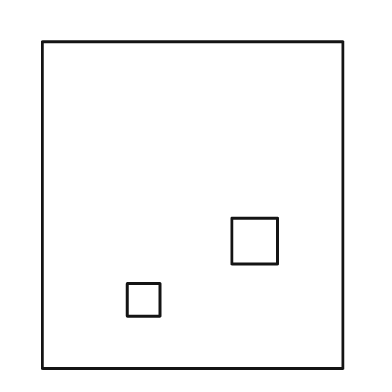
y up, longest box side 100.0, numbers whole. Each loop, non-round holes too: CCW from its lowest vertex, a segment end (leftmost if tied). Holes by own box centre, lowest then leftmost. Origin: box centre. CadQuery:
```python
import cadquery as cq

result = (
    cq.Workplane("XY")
    .moveTo(-46.0, -50.0)
    .lineTo(46.0, -50.0)
    .lineTo(46.0, 50.0)
    .lineTo(-46.0, 50.0)
    .close()
    .moveTo(-20.0, -34.0)
    .lineTo(-10.0, -34.0)
    .lineTo(-10.0, -24.0)
    .lineTo(-20.0, -24.0)
    .close()
    .moveTo(12.0, -18.0)
    .lineTo(26.0, -18.0)
    .lineTo(26.0, -4.0)
    .lineTo(12.0, -4.0)
    .close()
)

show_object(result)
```